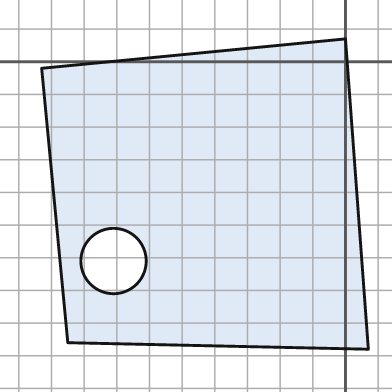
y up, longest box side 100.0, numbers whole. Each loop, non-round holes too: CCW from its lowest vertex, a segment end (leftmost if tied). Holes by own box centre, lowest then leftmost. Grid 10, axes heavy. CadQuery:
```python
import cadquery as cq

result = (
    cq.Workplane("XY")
    .moveTo(7.0, -88.0)
    .lineTo(0.0, 7.0)
    .lineTo(-93.0, -2.0)
    .lineTo(-85.0, -86.0)
    .close()
    .moveTo(-71.0, -61.0)
    .circle(10.0)
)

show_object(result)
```